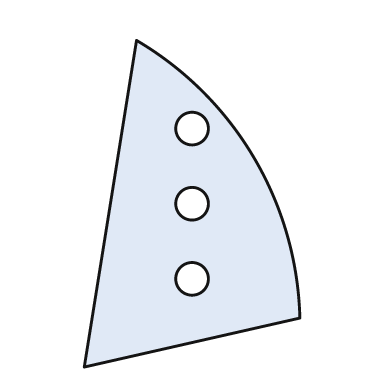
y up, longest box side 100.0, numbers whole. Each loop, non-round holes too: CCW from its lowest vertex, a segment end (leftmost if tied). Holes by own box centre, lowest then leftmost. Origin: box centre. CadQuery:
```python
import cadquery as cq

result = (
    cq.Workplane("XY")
    .moveTo(-33.0, -50.0)
    .lineTo(33.0, -35.0)
    .threePointArc((19.0, 14.0), (-17.0, 50.0))
    .close()
    .moveTo(0.0, -23.0)
    .circle(5.0)
    .moveTo(0.0, 0.0)
    .circle(5.0)
    .moveTo(0.0, 23.0)
    .circle(5.0)
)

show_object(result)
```